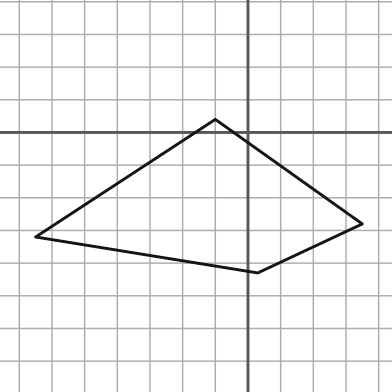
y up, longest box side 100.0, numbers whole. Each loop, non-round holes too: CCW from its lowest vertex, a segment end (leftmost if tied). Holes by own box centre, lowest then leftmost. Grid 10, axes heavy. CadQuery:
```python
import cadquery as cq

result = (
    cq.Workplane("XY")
    .moveTo(3.0, -43.0)
    .lineTo(35.0, -28.0)
    .lineTo(-10.0, 4.0)
    .lineTo(-65.0, -32.0)
    .close()
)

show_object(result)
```